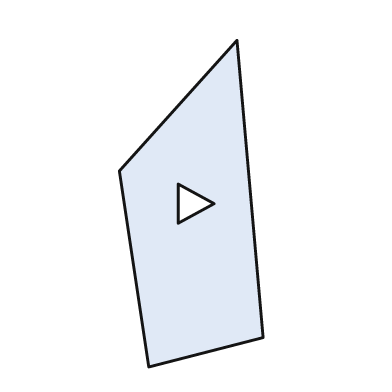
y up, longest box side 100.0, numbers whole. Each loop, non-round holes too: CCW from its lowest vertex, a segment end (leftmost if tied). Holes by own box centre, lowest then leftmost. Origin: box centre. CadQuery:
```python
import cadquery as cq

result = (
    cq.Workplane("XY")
    .moveTo(-13.0, -50.0)
    .lineTo(22.0, -41.0)
    .lineTo(14.0, 50.0)
    .lineTo(-22.0, 10.0)
    .close()
    .moveTo(-4.0, -6.0)
    .lineTo(7.0, 0.0)
    .lineTo(-4.0, 6.0)
    .close()
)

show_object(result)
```